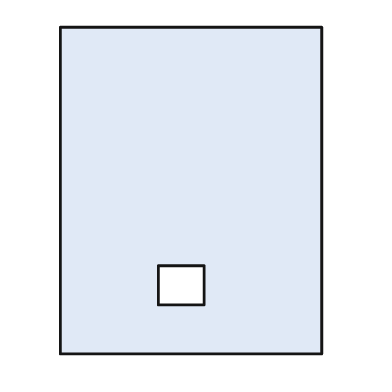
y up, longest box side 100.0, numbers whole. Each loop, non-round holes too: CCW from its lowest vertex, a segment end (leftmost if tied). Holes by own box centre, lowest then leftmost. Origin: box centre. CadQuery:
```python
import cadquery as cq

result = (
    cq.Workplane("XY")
    .moveTo(-40.0, -50.0)
    .lineTo(40.0, -50.0)
    .lineTo(40.0, 50.0)
    .lineTo(-40.0, 50.0)
    .close()
    .moveTo(-10.0, -35.0)
    .lineTo(4.0, -35.0)
    .lineTo(4.0, -23.0)
    .lineTo(-10.0, -23.0)
    .close()
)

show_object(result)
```